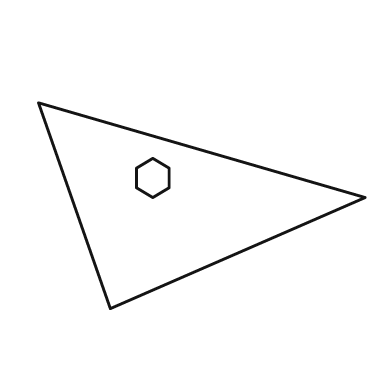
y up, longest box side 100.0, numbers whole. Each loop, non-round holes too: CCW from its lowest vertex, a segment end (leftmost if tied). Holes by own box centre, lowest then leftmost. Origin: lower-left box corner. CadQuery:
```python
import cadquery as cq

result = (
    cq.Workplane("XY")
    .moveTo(22.0, 0.0)
    .lineTo(100.0, 34.0)
    .lineTo(0.0, 63.0)
    .close()
    .moveTo(35.0, 34.0)
    .lineTo(40.0, 37.0)
    .lineTo(40.0, 43.0)
    .lineTo(35.0, 46.0)
    .lineTo(30.0, 43.0)
    .lineTo(30.0, 37.0)
    .close()
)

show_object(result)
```